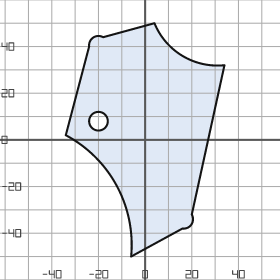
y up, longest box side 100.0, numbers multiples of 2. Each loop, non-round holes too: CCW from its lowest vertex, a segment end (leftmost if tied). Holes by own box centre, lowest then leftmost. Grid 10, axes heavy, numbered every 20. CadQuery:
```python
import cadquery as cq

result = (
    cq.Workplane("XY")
    .moveTo(-6.0, -50.0)
    .lineTo(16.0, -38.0)
    .threePointArc((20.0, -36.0), (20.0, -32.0))
    .lineTo(34.0, 32.0)
    .threePointArc((16.0, 36.0), (4.0, 50.0))
    .lineTo(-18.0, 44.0)
    .threePointArc((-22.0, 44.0), (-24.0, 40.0))
    .lineTo(-34.0, 2.0)
    .threePointArc((-12.0, -20.0), (-6.0, -50.0))
    .close()
    .moveTo(-20.0, 8.0)
    .circle(4.0)
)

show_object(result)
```